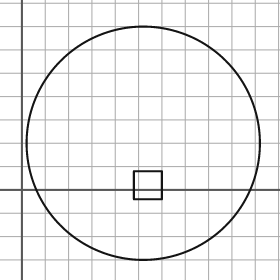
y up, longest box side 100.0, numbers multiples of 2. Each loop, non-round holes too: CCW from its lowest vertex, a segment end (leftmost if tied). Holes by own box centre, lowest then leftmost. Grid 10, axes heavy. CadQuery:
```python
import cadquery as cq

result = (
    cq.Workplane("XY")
    .moveTo(52.0, 20.0)
    .circle(50.0)
    .moveTo(48.0, -4.0)
    .lineTo(60.0, -4.0)
    .lineTo(60.0, 8.0)
    .lineTo(48.0, 8.0)
    .close()
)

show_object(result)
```